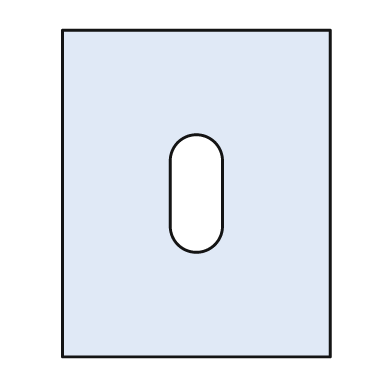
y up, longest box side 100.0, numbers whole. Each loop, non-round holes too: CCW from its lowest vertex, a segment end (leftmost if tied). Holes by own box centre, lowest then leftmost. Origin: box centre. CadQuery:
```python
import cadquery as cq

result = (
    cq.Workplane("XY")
    .moveTo(-41.0, -50.0)
    .lineTo(41.0, -50.0)
    .lineTo(41.0, 50.0)
    .lineTo(-41.0, 50.0)
    .close()
    .moveTo(-8.0, -10.0)
    .threePointArc((0.0, -18.0), (8.0, -10.0))
    .lineTo(8.0, 10.0)
    .threePointArc((0.0, 18.0), (-8.0, 10.0))
    .close()
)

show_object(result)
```